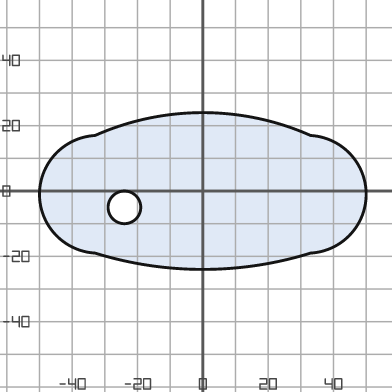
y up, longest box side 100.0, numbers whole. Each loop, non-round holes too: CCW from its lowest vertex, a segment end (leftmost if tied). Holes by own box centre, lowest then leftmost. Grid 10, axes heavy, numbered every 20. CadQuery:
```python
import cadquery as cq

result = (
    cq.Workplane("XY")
    .moveTo(-33.0, -19.0)
    .threePointArc((0.0, -24.0), (33.0, -19.0))
    .threePointArc((50.0, -1.0), (33.0, 17.0))
    .threePointArc((0.0, 24.0), (-33.0, 17.0))
    .threePointArc((-50.0, -1.0), (-33.0, -19.0))
    .close()
    .moveTo(-24.0, -5.0)
    .circle(5.0)
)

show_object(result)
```